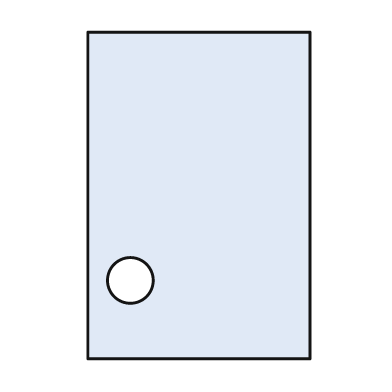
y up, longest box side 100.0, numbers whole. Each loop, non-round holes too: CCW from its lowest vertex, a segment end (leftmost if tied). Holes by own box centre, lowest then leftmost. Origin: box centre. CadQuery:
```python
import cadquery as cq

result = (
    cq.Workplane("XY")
    .moveTo(-34.0, -50.0)
    .lineTo(34.0, -50.0)
    .lineTo(34.0, 50.0)
    .lineTo(-34.0, 50.0)
    .close()
    .moveTo(-21.0, -26.0)
    .circle(7.0)
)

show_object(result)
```